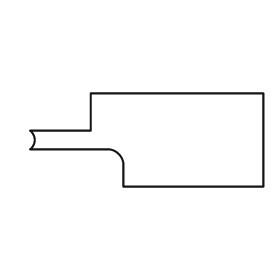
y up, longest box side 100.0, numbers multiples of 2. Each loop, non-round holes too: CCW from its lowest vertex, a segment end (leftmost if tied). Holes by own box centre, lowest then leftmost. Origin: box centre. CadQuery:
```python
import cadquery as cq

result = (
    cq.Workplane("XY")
    .moveTo(-10.0, -20.0)
    .lineTo(50.0, -20.0)
    .lineTo(50.0, 20.0)
    .lineTo(-24.0, 20.0)
    .lineTo(-24.0, 4.0)
    .lineTo(-50.0, 4.0)
    .threePointArc((-48.0, 0.0), (-50.0, -4.0))
    .lineTo(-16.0, -4.0)
    .threePointArc((-12.0, -6.0), (-10.0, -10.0))
    .close()
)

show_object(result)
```